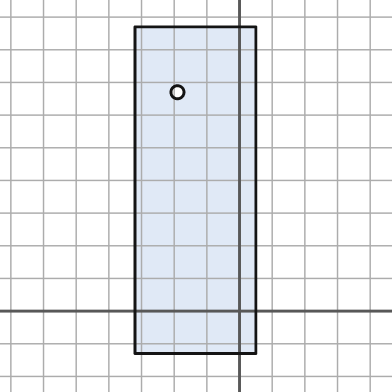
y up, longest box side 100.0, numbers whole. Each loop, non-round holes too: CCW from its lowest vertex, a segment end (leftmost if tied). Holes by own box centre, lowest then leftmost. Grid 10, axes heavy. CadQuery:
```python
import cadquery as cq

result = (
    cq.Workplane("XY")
    .moveTo(-32.0, -13.0)
    .lineTo(5.0, -13.0)
    .lineTo(5.0, 87.0)
    .lineTo(-32.0, 87.0)
    .close()
    .moveTo(-19.0, 67.0)
    .circle(2.0)
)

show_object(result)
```